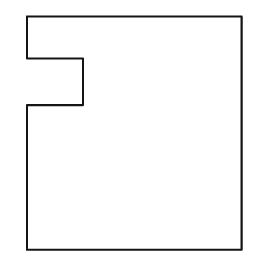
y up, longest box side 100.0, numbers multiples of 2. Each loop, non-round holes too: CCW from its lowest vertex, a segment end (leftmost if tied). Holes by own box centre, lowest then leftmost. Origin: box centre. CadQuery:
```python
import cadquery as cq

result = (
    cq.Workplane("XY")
    .moveTo(-46.0, -50.0)
    .lineTo(46.0, -50.0)
    .lineTo(46.0, 50.0)
    .lineTo(-46.0, 50.0)
    .lineTo(-46.0, 32.0)
    .lineTo(-22.0, 32.0)
    .lineTo(-22.0, 12.0)
    .lineTo(-46.0, 12.0)
    .close()
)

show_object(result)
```